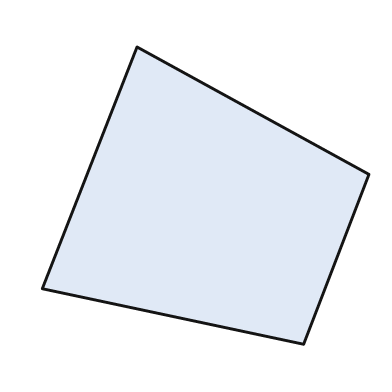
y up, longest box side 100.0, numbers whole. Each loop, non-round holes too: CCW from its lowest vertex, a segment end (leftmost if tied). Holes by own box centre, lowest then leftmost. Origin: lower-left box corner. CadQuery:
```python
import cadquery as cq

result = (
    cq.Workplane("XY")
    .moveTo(80.0, 0.0)
    .lineTo(100.0, 52.0)
    .lineTo(29.0, 91.0)
    .lineTo(0.0, 17.0)
    .close()
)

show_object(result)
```